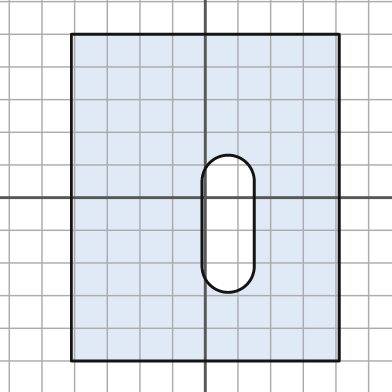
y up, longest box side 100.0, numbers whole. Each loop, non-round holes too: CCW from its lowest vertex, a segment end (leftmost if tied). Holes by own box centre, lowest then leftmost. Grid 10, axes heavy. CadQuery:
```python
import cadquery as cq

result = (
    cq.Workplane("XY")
    .moveTo(-41.0, -50.0)
    .lineTo(41.0, -50.0)
    .lineTo(41.0, 50.0)
    .lineTo(-41.0, 50.0)
    .close()
    .moveTo(-1.0, -21.0)
    .threePointArc((7.0, -29.0), (15.0, -21.0))
    .lineTo(15.0, 5.0)
    .threePointArc((7.0, 13.0), (-1.0, 5.0))
    .close()
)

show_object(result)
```